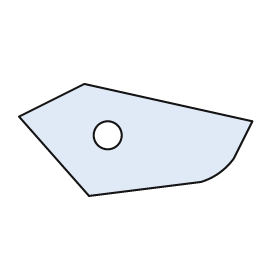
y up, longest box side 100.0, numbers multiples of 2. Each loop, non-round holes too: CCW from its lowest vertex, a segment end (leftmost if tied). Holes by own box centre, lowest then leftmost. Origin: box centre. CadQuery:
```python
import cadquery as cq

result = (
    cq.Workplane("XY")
    .moveTo(-20.0, -24.0)
    .lineTo(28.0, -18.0)
    .threePointArc((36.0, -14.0), (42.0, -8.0))
    .lineTo(50.0, 8.0)
    .lineTo(-22.0, 24.0)
    .lineTo(-50.0, 10.0)
    .close()
    .moveTo(-12.0, 2.0)
    .circle(6.0)
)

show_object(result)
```